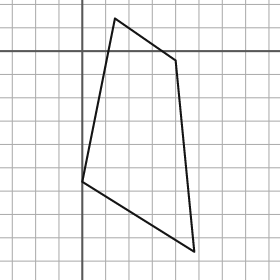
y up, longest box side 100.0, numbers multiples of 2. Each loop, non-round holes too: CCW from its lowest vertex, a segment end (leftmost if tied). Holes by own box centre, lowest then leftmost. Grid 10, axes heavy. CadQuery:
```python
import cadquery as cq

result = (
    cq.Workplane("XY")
    .moveTo(48.0, -86.0)
    .lineTo(40.0, -4.0)
    .lineTo(14.0, 14.0)
    .lineTo(0.0, -56.0)
    .close()
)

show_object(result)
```